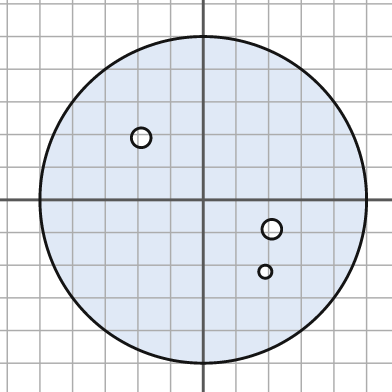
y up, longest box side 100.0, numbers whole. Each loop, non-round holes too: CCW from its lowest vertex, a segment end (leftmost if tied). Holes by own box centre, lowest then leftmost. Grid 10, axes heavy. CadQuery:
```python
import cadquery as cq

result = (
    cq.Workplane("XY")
    .moveTo(0.0, 0.0)
    .circle(50.0)
    .moveTo(19.0, -22.0)
    .circle(2.0)
    .moveTo(21.0, -9.0)
    .circle(3.0)
    .moveTo(-19.0, 19.0)
    .circle(3.0)
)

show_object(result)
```